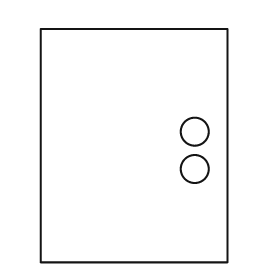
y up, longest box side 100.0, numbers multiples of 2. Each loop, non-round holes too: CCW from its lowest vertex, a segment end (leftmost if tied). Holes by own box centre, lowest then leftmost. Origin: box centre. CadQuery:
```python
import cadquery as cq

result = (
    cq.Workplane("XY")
    .moveTo(-40.0, -50.0)
    .lineTo(40.0, -50.0)
    .lineTo(40.0, 50.0)
    .lineTo(-40.0, 50.0)
    .close()
    .moveTo(26.0, -10.0)
    .circle(6.0)
    .moveTo(26.0, 6.0)
    .circle(6.0)
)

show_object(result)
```